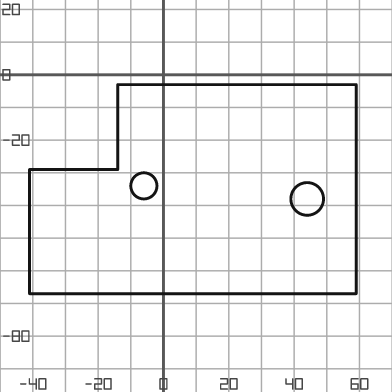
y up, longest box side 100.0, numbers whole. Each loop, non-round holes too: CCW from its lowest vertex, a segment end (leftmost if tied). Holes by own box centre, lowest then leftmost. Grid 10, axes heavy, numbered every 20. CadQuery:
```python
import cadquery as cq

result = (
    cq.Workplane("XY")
    .moveTo(-41.0, -67.0)
    .lineTo(59.0, -67.0)
    .lineTo(59.0, -3.0)
    .lineTo(-14.0, -3.0)
    .lineTo(-14.0, -29.0)
    .lineTo(-41.0, -29.0)
    .close()
    .moveTo(44.0, -38.0)
    .circle(5.0)
    .moveTo(-6.0, -34.0)
    .circle(4.0)
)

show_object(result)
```